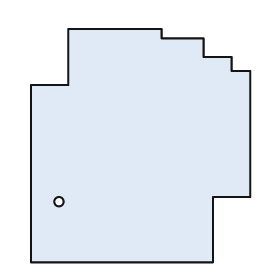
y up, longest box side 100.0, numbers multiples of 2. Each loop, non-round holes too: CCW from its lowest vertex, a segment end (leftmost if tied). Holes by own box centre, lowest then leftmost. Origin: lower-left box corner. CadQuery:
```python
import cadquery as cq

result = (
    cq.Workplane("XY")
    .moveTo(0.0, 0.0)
    .lineTo(78.0, 0.0)
    .lineTo(78.0, 28.0)
    .lineTo(94.0, 28.0)
    .lineTo(94.0, 82.0)
    .lineTo(86.0, 82.0)
    .lineTo(86.0, 88.0)
    .lineTo(74.0, 88.0)
    .lineTo(74.0, 96.0)
    .lineTo(56.0, 96.0)
    .lineTo(56.0, 100.0)
    .lineTo(16.0, 100.0)
    .lineTo(16.0, 76.0)
    .lineTo(0.0, 76.0)
    .close()
    .moveTo(12.0, 26.0)
    .circle(2.0)
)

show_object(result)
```